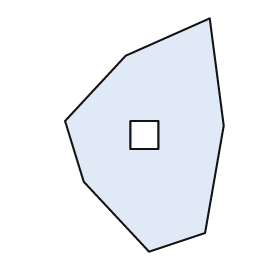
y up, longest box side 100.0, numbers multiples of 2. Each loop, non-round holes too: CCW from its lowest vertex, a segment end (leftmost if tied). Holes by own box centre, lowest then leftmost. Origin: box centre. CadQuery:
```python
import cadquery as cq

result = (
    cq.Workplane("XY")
    .moveTo(2.0, -50.0)
    .lineTo(26.0, -42.0)
    .lineTo(34.0, 4.0)
    .lineTo(28.0, 50.0)
    .lineTo(-8.0, 34.0)
    .lineTo(-34.0, 6.0)
    .lineTo(-26.0, -20.0)
    .close()
    .moveTo(-6.0, -6.0)
    .lineTo(6.0, -6.0)
    .lineTo(6.0, 6.0)
    .lineTo(-6.0, 6.0)
    .close()
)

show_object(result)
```